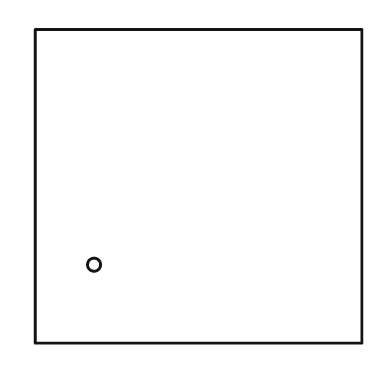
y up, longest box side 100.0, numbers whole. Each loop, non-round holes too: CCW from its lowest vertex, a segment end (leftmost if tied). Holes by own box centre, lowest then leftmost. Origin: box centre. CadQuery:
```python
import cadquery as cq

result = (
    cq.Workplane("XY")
    .moveTo(-50.0, -48.0)
    .lineTo(50.0, -48.0)
    .lineTo(50.0, 48.0)
    .lineTo(-50.0, 48.0)
    .close()
    .moveTo(-32.0, -24.0)
    .circle(2.0)
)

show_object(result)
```